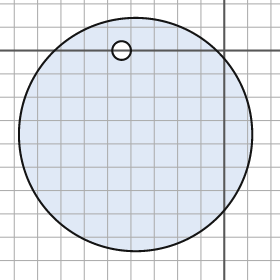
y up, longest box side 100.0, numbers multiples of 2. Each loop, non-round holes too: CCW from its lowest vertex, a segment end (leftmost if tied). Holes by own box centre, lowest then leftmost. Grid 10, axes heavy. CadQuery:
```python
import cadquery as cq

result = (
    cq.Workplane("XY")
    .moveTo(-38.0, -36.0)
    .circle(50.0)
    .moveTo(-44.0, 0.0)
    .circle(4.0)
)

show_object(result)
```